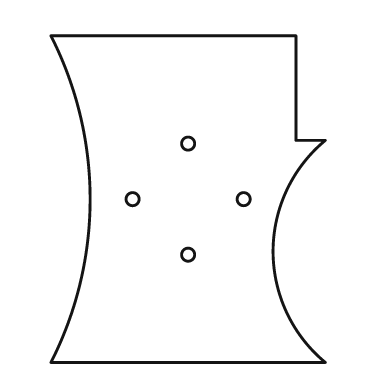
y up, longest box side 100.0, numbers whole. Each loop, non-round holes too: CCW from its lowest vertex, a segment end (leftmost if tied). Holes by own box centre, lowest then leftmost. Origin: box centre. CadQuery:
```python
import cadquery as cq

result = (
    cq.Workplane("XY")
    .moveTo(-42.0, -50.0)
    .lineTo(42.0, -50.0)
    .threePointArc((26.0, -16.0), (42.0, 18.0))
    .lineTo(33.0, 18.0)
    .lineTo(33.0, 50.0)
    .lineTo(-42.0, 50.0)
    .threePointArc((-30.0, 0.0), (-42.0, -50.0))
    .close()
    .moveTo(0.0, -17.0)
    .circle(2.0)
    .moveTo(-17.0, 0.0)
    .circle(2.0)
    .moveTo(17.0, 0.0)
    .circle(2.0)
    .moveTo(0.0, 17.0)
    .circle(2.0)
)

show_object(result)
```